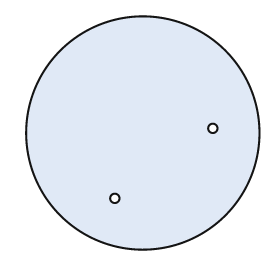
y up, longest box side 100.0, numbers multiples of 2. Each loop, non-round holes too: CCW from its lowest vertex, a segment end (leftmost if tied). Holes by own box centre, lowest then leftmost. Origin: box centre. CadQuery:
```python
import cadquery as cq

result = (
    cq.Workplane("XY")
    .moveTo(0.0, 0.0)
    .circle(50.0)
    .moveTo(-12.0, -28.0)
    .circle(2.0)
    .moveTo(30.0, 2.0)
    .circle(2.0)
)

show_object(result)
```